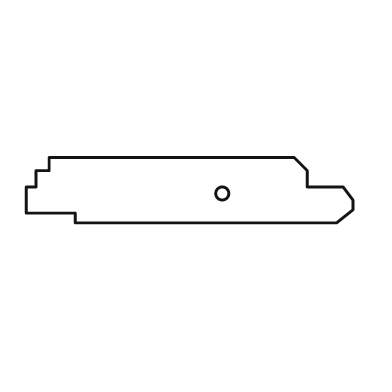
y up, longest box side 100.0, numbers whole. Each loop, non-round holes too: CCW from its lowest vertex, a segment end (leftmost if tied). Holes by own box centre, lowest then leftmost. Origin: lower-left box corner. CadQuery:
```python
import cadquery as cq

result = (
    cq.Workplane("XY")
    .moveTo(15.0, 0.0)
    .lineTo(95.0, 0.0)
    .lineTo(100.0, 4.0)
    .lineTo(100.0, 7.0)
    .lineTo(97.0, 11.0)
    .lineTo(86.0, 11.0)
    .lineTo(86.0, 16.0)
    .lineTo(82.0, 20.0)
    .lineTo(7.0, 20.0)
    .lineTo(7.0, 16.0)
    .lineTo(3.0, 16.0)
    .lineTo(3.0, 11.0)
    .lineTo(0.0, 11.0)
    .lineTo(0.0, 3.0)
    .lineTo(15.0, 3.0)
    .close()
    .moveTo(60.0, 9.0)
    .circle(2.0)
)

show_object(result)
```